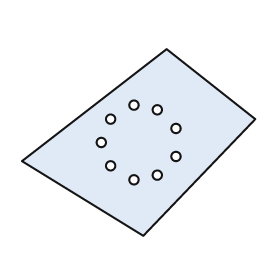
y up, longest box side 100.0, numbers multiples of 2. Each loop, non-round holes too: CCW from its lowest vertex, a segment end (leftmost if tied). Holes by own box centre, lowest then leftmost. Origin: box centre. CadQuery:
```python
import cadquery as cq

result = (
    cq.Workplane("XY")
    .moveTo(2.0, -40.0)
    .lineTo(50.0, 10.0)
    .lineTo(12.0, 40.0)
    .lineTo(-50.0, -8.0)
    .close()
    .moveTo(-2.0, -16.0)
    .circle(2.0)
    .moveTo(8.0, -14.0)
    .circle(2.0)
    .moveTo(-12.0, -10.0)
    .circle(2.0)
    .moveTo(16.0, -6.0)
    .circle(2.0)
    .moveTo(-16.0, 0.0)
    .circle(2.0)
    .moveTo(16.0, 6.0)
    .circle(2.0)
    .moveTo(-12.0, 10.0)
    .circle(2.0)
    .moveTo(8.0, 14.0)
    .circle(2.0)
    .moveTo(-2.0, 16.0)
    .circle(2.0)
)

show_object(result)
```